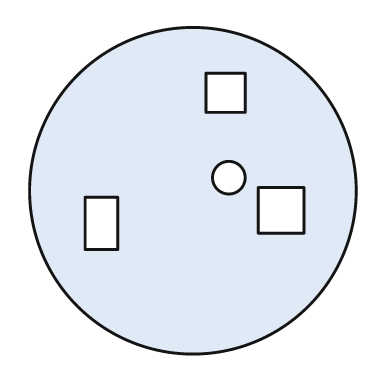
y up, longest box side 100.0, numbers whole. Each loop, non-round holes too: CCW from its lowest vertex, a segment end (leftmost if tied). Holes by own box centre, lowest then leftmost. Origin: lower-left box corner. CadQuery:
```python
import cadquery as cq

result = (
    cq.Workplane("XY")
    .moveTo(50.0, 50.0)
    .circle(50.0)
    .moveTo(17.0, 32.0)
    .lineTo(27.0, 32.0)
    .lineTo(27.0, 48.0)
    .lineTo(17.0, 48.0)
    .close()
    .moveTo(70.0, 37.0)
    .lineTo(84.0, 37.0)
    .lineTo(84.0, 51.0)
    .lineTo(70.0, 51.0)
    .close()
    .moveTo(61.0, 54.0)
    .circle(5.0)
    .moveTo(54.0, 74.0)
    .lineTo(66.0, 74.0)
    .lineTo(66.0, 86.0)
    .lineTo(54.0, 86.0)
    .close()
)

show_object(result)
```